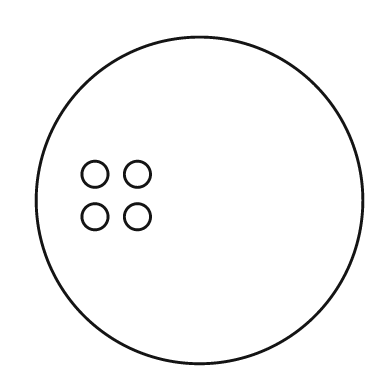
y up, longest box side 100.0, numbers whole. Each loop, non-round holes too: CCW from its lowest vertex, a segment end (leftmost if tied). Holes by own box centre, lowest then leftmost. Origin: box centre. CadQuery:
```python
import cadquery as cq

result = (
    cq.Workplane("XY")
    .moveTo(0.0, 0.0)
    .circle(50.0)
    .moveTo(-32.0, -5.0)
    .circle(4.0)
    .moveTo(-19.0, -5.0)
    .circle(4.0)
    .moveTo(-32.0, 8.0)
    .circle(4.0)
    .moveTo(-19.0, 8.0)
    .circle(4.0)
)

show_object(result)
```